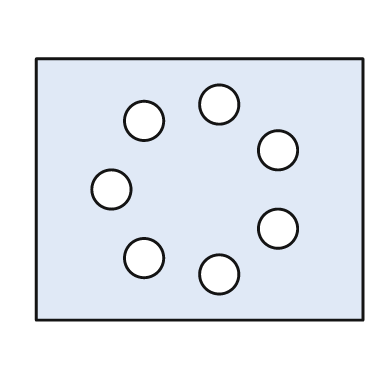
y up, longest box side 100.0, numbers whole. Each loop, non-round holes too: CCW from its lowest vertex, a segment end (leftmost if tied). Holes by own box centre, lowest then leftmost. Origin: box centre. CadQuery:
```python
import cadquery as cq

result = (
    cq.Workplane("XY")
    .moveTo(-50.0, -40.0)
    .lineTo(50.0, -40.0)
    .lineTo(50.0, 40.0)
    .lineTo(-50.0, 40.0)
    .close()
    .moveTo(6.0, -26.0)
    .circle(6.0)
    .moveTo(-17.0, -21.0)
    .circle(6.0)
    .moveTo(24.0, -12.0)
    .circle(6.0)
    .moveTo(-27.0, 0.0)
    .circle(6.0)
    .moveTo(24.0, 12.0)
    .circle(6.0)
    .moveTo(-17.0, 21.0)
    .circle(6.0)
    .moveTo(6.0, 26.0)
    .circle(6.0)
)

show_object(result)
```